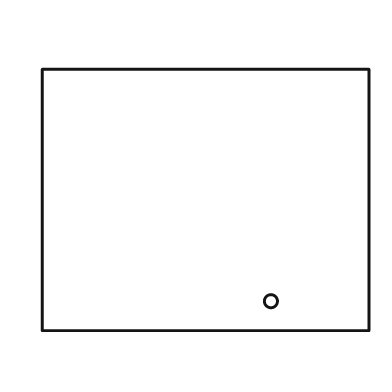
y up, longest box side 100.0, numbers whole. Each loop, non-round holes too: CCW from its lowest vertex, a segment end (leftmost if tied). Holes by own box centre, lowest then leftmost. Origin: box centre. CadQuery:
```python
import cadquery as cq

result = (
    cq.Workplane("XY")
    .moveTo(-50.0, -40.0)
    .lineTo(50.0, -40.0)
    .lineTo(50.0, 40.0)
    .lineTo(-50.0, 40.0)
    .close()
    .moveTo(20.0, -31.0)
    .circle(2.0)
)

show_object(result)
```